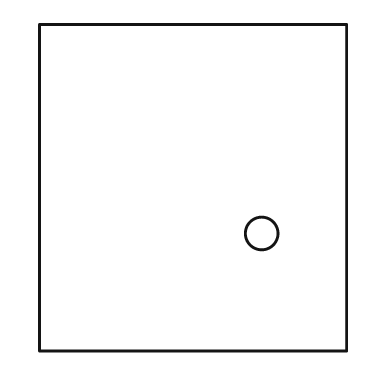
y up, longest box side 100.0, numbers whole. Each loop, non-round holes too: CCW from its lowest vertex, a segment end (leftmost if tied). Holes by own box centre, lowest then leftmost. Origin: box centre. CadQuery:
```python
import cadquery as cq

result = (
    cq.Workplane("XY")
    .moveTo(-47.0, -50.0)
    .lineTo(47.0, -50.0)
    .lineTo(47.0, 50.0)
    .lineTo(-47.0, 50.0)
    .close()
    .moveTo(21.0, -14.0)
    .circle(5.0)
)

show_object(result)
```